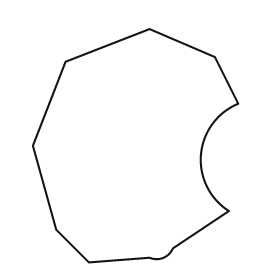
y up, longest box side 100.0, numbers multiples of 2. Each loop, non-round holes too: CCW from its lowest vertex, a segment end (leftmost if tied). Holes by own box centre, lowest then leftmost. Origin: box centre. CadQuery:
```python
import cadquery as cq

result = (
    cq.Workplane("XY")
    .moveTo(-20.0, -50.0)
    .lineTo(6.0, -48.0)
    .threePointArc((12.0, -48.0), (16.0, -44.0))
    .lineTo(40.0, -28.0)
    .threePointArc((28.0, -4.0), (44.0, 18.0))
    .lineTo(34.0, 38.0)
    .lineTo(6.0, 50.0)
    .lineTo(-30.0, 36.0)
    .lineTo(-44.0, 0.0)
    .lineTo(-34.0, -36.0)
    .close()
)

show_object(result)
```